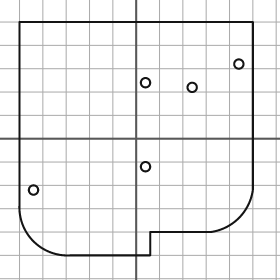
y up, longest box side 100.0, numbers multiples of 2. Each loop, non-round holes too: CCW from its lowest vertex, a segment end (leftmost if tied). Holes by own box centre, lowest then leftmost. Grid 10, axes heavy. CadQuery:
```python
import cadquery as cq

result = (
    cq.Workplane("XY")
    .moveTo(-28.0, -50.0)
    .lineTo(6.0, -50.0)
    .lineTo(6.0, -40.0)
    .lineTo(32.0, -40.0)
    .threePointArc((44.0, -34.0), (50.0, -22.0))
    .lineTo(50.0, 50.0)
    .lineTo(-50.0, 50.0)
    .lineTo(-50.0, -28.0)
    .threePointArc((-44.0, -44.0), (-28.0, -50.0))
    .close()
    .moveTo(-44.0, -22.0)
    .circle(2.0)
    .moveTo(4.0, -12.0)
    .circle(2.0)
    .moveTo(24.0, 22.0)
    .circle(2.0)
    .moveTo(4.0, 24.0)
    .circle(2.0)
    .moveTo(44.0, 32.0)
    .circle(2.0)
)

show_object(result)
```